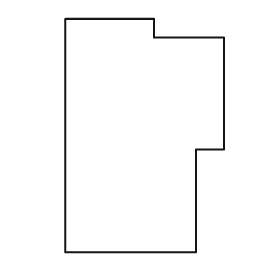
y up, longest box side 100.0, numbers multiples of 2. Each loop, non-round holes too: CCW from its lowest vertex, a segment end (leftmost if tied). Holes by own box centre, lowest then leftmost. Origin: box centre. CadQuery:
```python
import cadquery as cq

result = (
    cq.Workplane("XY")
    .moveTo(-34.0, -50.0)
    .lineTo(22.0, -50.0)
    .lineTo(22.0, -6.0)
    .lineTo(34.0, -6.0)
    .lineTo(34.0, 42.0)
    .lineTo(4.0, 42.0)
    .lineTo(4.0, 50.0)
    .lineTo(-34.0, 50.0)
    .close()
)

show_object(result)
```